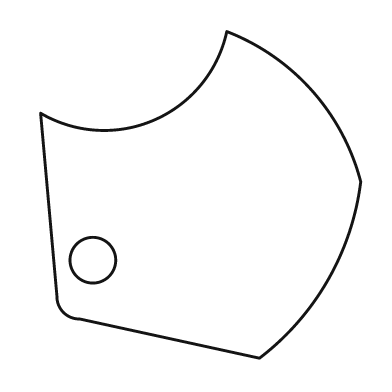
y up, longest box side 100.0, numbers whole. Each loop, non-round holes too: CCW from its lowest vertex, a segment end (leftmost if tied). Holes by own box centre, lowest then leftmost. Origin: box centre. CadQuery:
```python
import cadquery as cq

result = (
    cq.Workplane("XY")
    .moveTo(18.0, -50.0)
    .threePointArc((39.0, -26.0), (49.0, 4.0))
    .threePointArc((34.0, 32.0), (8.0, 50.0))
    .threePointArc((-14.0, 23.0), (-49.0, 25.0))
    .lineTo(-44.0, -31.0)
    .threePointArc((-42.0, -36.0), (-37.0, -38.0))
    .close()
    .moveTo(-33.0, -20.0)
    .circle(7.0)
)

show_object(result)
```